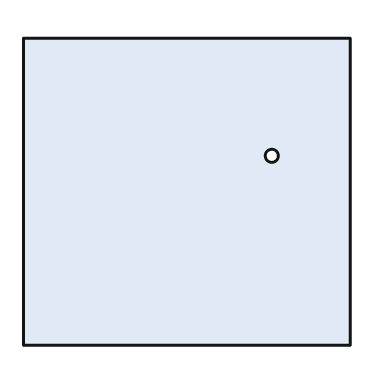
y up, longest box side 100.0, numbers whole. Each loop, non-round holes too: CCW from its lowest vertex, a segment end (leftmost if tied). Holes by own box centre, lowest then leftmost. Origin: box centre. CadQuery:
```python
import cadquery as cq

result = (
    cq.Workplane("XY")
    .moveTo(-50.0, -47.0)
    .lineTo(50.0, -47.0)
    .lineTo(50.0, 47.0)
    .lineTo(-50.0, 47.0)
    .close()
    .moveTo(26.0, 11.0)
    .circle(2.0)
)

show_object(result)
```